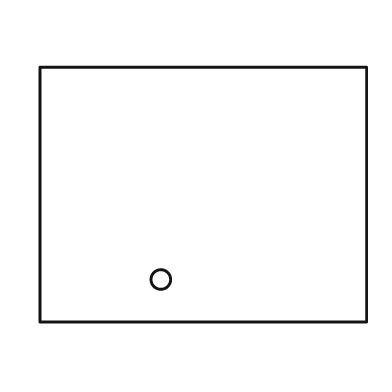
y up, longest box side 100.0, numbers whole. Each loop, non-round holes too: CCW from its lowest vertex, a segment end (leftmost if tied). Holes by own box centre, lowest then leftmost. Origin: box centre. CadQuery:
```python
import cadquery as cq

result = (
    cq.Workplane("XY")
    .moveTo(-50.0, -39.0)
    .lineTo(50.0, -39.0)
    .lineTo(50.0, 39.0)
    .lineTo(-50.0, 39.0)
    .close()
    .moveTo(-13.0, -26.0)
    .circle(3.0)
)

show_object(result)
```